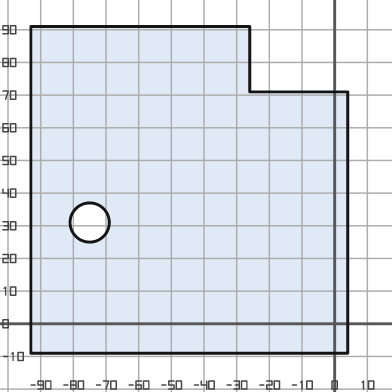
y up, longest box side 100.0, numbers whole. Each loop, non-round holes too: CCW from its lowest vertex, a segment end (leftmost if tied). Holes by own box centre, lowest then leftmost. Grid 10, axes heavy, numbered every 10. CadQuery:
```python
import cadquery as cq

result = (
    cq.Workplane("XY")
    .moveTo(-93.0, -9.0)
    .lineTo(4.0, -9.0)
    .lineTo(4.0, 71.0)
    .lineTo(-26.0, 71.0)
    .lineTo(-26.0, 91.0)
    .lineTo(-93.0, 91.0)
    .close()
    .moveTo(-75.0, 31.0)
    .circle(6.0)
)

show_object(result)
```